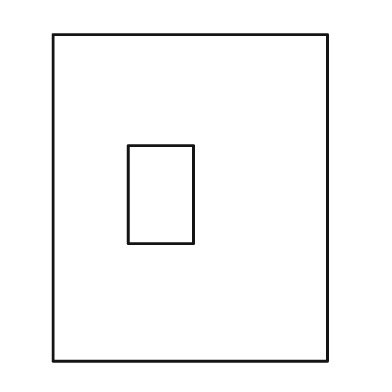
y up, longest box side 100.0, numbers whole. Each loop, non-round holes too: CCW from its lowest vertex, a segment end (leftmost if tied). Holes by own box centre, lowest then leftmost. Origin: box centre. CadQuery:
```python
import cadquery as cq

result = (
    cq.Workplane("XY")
    .moveTo(-42.0, -50.0)
    .lineTo(42.0, -50.0)
    .lineTo(42.0, 50.0)
    .lineTo(-42.0, 50.0)
    .close()
    .moveTo(-19.0, -14.0)
    .lineTo(1.0, -14.0)
    .lineTo(1.0, 16.0)
    .lineTo(-19.0, 16.0)
    .close()
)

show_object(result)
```